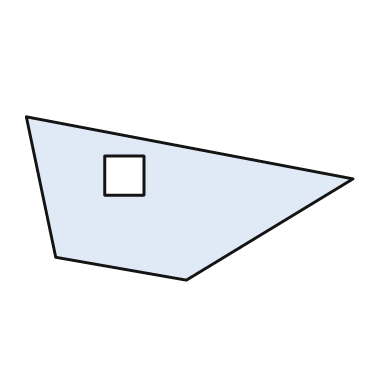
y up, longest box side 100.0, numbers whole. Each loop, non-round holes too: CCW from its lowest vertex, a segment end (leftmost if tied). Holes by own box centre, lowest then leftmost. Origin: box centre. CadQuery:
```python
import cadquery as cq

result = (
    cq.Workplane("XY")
    .moveTo(-1.0, -25.0)
    .lineTo(50.0, 6.0)
    .lineTo(-50.0, 25.0)
    .lineTo(-41.0, -18.0)
    .close()
    .moveTo(-26.0, 1.0)
    .lineTo(-14.0, 1.0)
    .lineTo(-14.0, 13.0)
    .lineTo(-26.0, 13.0)
    .close()
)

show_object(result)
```